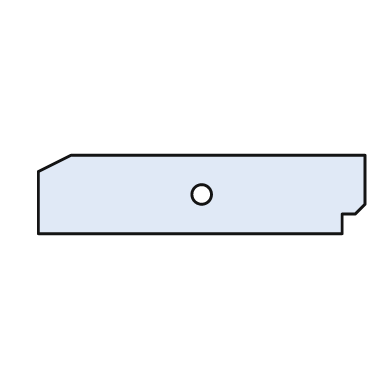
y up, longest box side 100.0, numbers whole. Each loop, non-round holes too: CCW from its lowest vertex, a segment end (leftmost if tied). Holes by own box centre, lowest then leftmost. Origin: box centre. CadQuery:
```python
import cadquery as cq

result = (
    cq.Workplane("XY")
    .moveTo(-50.0, -12.0)
    .lineTo(43.0, -12.0)
    .lineTo(43.0, -6.0)
    .lineTo(47.0, -6.0)
    .lineTo(50.0, -3.0)
    .lineTo(50.0, 12.0)
    .lineTo(-40.0, 12.0)
    .lineTo(-50.0, 7.0)
    .close()
    .moveTo(0.0, 0.0)
    .circle(3.0)
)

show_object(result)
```